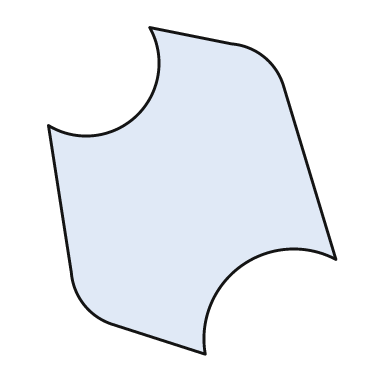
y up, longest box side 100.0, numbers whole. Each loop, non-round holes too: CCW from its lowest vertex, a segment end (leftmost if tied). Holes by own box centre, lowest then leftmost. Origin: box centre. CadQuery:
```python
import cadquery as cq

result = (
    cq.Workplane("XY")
    .moveTo(4.0, -50.0)
    .threePointArc((15.0, -23.0), (44.0, -21.0))
    .lineTo(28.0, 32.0)
    .threePointArc((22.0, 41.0), (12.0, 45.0))
    .lineTo(-13.0, 50.0)
    .threePointArc((-17.0, 23.0), (-44.0, 20.0))
    .lineTo(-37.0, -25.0)
    .threePointArc((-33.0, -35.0), (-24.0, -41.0))
    .close()
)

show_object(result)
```